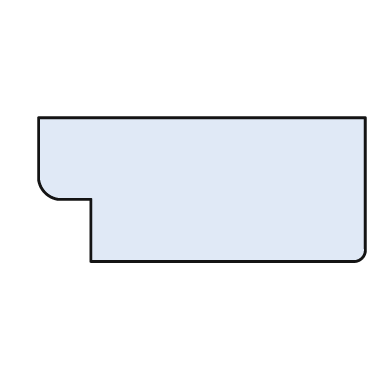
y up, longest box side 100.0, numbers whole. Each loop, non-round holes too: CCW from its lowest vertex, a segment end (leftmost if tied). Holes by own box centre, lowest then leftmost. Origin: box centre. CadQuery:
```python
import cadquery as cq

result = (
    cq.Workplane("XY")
    .moveTo(-34.0, -22.0)
    .lineTo(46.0, -22.0)
    .threePointArc((49.0, -21.0), (50.0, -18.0))
    .lineTo(50.0, 22.0)
    .lineTo(-50.0, 22.0)
    .lineTo(-50.0, 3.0)
    .threePointArc((-48.0, -1.0), (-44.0, -3.0))
    .lineTo(-34.0, -3.0)
    .close()
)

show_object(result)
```